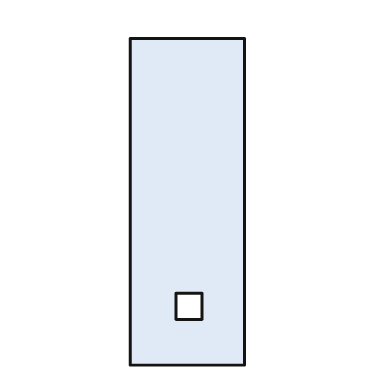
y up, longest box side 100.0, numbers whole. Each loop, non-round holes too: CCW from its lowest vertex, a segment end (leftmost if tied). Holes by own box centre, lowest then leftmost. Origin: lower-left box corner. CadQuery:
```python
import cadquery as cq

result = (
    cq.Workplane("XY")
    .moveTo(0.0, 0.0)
    .lineTo(35.0, 0.0)
    .lineTo(35.0, 100.0)
    .lineTo(0.0, 100.0)
    .close()
    .moveTo(14.0, 14.0)
    .lineTo(22.0, 14.0)
    .lineTo(22.0, 22.0)
    .lineTo(14.0, 22.0)
    .close()
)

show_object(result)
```